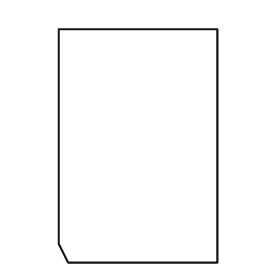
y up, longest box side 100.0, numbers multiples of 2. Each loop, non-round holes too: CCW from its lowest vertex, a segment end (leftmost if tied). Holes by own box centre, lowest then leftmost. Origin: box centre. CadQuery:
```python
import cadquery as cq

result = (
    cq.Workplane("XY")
    .moveTo(-30.0, -50.0)
    .lineTo(34.0, -50.0)
    .lineTo(34.0, 50.0)
    .lineTo(-34.0, 50.0)
    .lineTo(-34.0, -42.0)
    .close()
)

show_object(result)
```